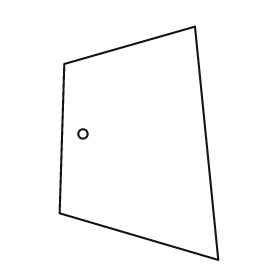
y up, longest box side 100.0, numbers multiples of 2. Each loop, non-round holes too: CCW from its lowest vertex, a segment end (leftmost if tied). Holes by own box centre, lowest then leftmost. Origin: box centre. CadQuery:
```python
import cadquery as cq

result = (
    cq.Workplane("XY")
    .moveTo(34.0, -50.0)
    .lineTo(24.0, 50.0)
    .lineTo(-32.0, 34.0)
    .lineTo(-34.0, -30.0)
    .close()
    .moveTo(-24.0, 4.0)
    .circle(2.0)
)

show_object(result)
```